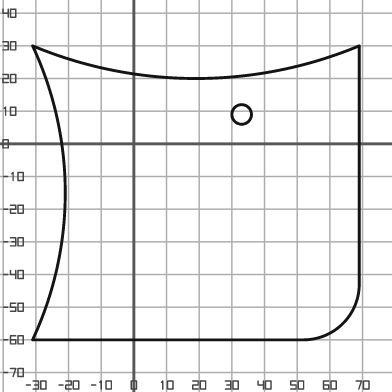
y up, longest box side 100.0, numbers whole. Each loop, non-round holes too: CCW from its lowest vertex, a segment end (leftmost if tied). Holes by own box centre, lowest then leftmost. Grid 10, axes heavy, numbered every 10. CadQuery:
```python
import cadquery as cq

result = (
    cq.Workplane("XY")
    .moveTo(-31.0, -60.0)
    .lineTo(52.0, -60.0)
    .threePointArc((64.0, -55.0), (69.0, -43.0))
    .lineTo(69.0, 30.0)
    .threePointArc((19.0, 20.0), (-31.0, 30.0))
    .threePointArc((-21.0, -15.0), (-31.0, -60.0))
    .close()
    .moveTo(33.0, 9.0)
    .circle(3.0)
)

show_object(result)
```